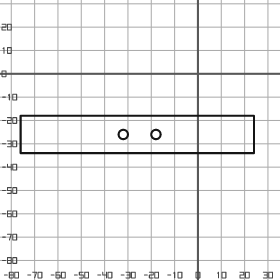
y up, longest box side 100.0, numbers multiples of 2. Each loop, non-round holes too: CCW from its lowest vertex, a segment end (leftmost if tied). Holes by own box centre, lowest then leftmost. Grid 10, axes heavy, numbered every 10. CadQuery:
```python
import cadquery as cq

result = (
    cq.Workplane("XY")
    .moveTo(-76.0, -34.0)
    .lineTo(24.0, -34.0)
    .lineTo(24.0, -18.0)
    .lineTo(-76.0, -18.0)
    .close()
    .moveTo(-32.0, -26.0)
    .circle(2.0)
    .moveTo(-18.0, -26.0)
    .circle(2.0)
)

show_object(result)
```